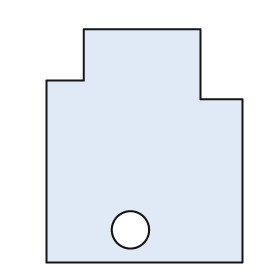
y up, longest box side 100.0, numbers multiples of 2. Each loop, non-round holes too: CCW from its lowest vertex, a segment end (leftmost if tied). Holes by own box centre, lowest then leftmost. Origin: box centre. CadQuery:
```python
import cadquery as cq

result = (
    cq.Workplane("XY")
    .moveTo(-42.0, -50.0)
    .lineTo(42.0, -50.0)
    .lineTo(42.0, 20.0)
    .lineTo(24.0, 20.0)
    .lineTo(24.0, 50.0)
    .lineTo(-26.0, 50.0)
    .lineTo(-26.0, 28.0)
    .lineTo(-42.0, 28.0)
    .close()
    .moveTo(-6.0, -36.0)
    .circle(8.0)
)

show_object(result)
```